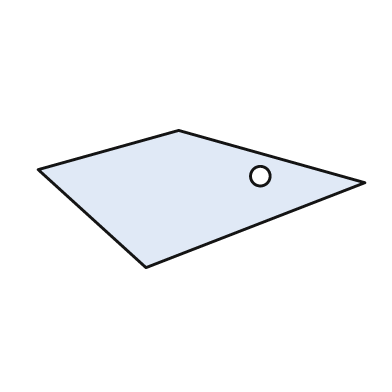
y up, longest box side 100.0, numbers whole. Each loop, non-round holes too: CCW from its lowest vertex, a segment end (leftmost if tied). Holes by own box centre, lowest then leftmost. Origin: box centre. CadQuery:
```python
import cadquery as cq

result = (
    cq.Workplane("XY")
    .moveTo(-17.0, -21.0)
    .lineTo(50.0, 5.0)
    .lineTo(-7.0, 21.0)
    .lineTo(-50.0, 9.0)
    .close()
    .moveTo(18.0, 7.0)
    .circle(3.0)
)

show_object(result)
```